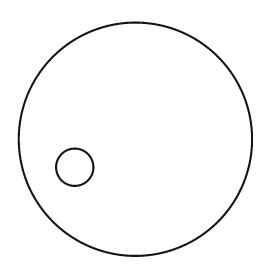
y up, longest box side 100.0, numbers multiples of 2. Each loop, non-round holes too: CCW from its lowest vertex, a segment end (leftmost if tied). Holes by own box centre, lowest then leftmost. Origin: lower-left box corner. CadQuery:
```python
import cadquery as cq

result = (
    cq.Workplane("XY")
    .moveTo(50.0, 50.0)
    .circle(50.0)
    .moveTo(24.0, 38.0)
    .circle(8.0)
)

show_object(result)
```